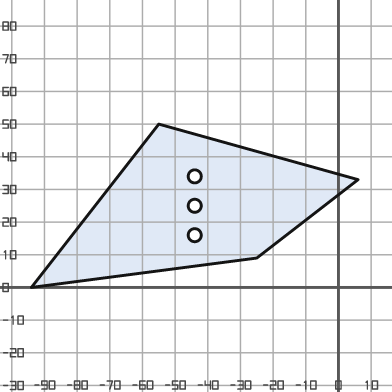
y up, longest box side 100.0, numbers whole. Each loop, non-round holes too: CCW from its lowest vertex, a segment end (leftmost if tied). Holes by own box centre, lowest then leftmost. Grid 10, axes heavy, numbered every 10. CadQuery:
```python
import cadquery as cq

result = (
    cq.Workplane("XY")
    .moveTo(-94.0, 0.0)
    .lineTo(-25.0, 9.0)
    .lineTo(6.0, 33.0)
    .lineTo(-55.0, 50.0)
    .close()
    .moveTo(-44.0, 16.0)
    .circle(2.0)
    .moveTo(-44.0, 25.0)
    .circle(2.0)
    .moveTo(-44.0, 34.0)
    .circle(2.0)
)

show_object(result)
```